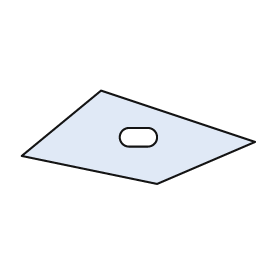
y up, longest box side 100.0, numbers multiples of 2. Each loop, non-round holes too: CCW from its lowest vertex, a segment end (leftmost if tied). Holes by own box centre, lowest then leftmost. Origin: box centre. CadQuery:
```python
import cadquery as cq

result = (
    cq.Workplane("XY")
    .moveTo(8.0, -20.0)
    .lineTo(50.0, -2.0)
    .lineTo(-16.0, 20.0)
    .lineTo(-50.0, -8.0)
    .close()
    .moveTo(-4.0, -4.0)
    .lineTo(4.0, -4.0)
    .threePointArc((8.0, 0.0), (4.0, 4.0))
    .lineTo(-4.0, 4.0)
    .threePointArc((-8.0, 0.0), (-4.0, -4.0))
    .close()
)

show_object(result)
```